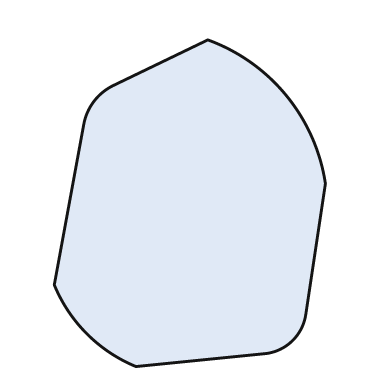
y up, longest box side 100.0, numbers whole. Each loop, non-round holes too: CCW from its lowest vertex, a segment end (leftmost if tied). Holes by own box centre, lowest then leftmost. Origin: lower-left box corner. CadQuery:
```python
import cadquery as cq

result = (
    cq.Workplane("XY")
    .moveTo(25.0, 0.0)
    .lineTo(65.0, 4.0)
    .threePointArc((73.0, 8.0), (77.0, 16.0))
    .lineTo(83.0, 56.0)
    .threePointArc((71.0, 83.0), (47.0, 100.0))
    .lineTo(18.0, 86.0)
    .threePointArc((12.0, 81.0), (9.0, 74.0))
    .lineTo(0.0, 25.0)
    .threePointArc((10.0, 10.0), (25.0, 0.0))
    .close()
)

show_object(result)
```